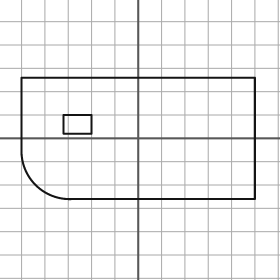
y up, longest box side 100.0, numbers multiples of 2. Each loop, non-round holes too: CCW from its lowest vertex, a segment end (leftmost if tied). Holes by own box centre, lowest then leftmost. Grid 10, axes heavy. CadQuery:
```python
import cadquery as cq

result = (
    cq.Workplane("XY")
    .moveTo(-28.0, -26.0)
    .lineTo(50.0, -26.0)
    .lineTo(50.0, 26.0)
    .lineTo(-50.0, 26.0)
    .lineTo(-50.0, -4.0)
    .threePointArc((-44.0, -20.0), (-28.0, -26.0))
    .close()
    .moveTo(-32.0, 2.0)
    .lineTo(-20.0, 2.0)
    .lineTo(-20.0, 10.0)
    .lineTo(-32.0, 10.0)
    .close()
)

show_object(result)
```